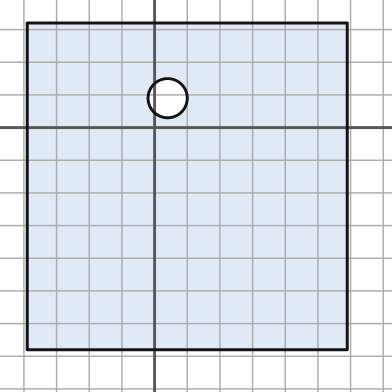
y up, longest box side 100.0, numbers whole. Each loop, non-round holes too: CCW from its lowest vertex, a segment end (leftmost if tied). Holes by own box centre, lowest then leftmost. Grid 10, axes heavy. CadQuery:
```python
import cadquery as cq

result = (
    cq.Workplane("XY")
    .moveTo(-39.0, -68.0)
    .lineTo(59.0, -68.0)
    .lineTo(59.0, 32.0)
    .lineTo(-39.0, 32.0)
    .close()
    .moveTo(4.0, 9.0)
    .circle(6.0)
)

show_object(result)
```